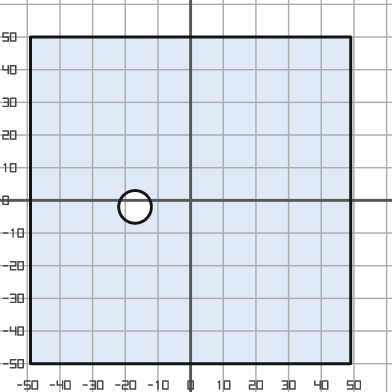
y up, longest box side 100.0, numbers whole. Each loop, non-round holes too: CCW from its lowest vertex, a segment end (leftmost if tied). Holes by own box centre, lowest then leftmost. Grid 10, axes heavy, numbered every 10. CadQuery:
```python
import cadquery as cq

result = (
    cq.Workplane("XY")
    .moveTo(-49.0, -50.0)
    .lineTo(49.0, -50.0)
    .lineTo(49.0, 50.0)
    .lineTo(-49.0, 50.0)
    .close()
    .moveTo(-17.0, -2.0)
    .circle(5.0)
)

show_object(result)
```